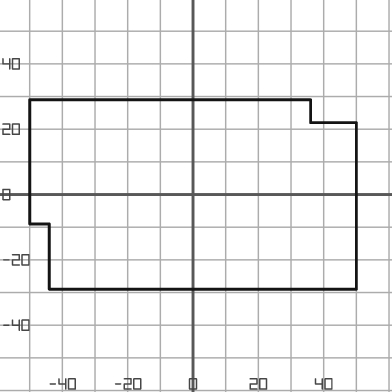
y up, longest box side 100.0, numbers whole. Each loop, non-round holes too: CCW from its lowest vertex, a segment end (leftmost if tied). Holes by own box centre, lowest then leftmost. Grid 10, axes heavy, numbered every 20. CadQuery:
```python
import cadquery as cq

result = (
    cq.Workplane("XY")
    .moveTo(-44.0, -29.0)
    .lineTo(50.0, -29.0)
    .lineTo(50.0, 22.0)
    .lineTo(36.0, 22.0)
    .lineTo(36.0, 29.0)
    .lineTo(-50.0, 29.0)
    .lineTo(-50.0, -9.0)
    .lineTo(-44.0, -9.0)
    .close()
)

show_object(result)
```